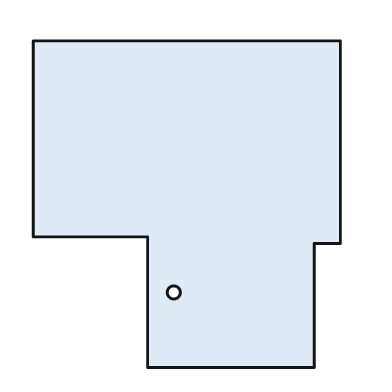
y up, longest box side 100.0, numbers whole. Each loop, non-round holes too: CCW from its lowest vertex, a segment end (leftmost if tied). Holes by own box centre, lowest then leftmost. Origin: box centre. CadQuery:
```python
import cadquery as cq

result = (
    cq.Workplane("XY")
    .moveTo(-12.0, -50.0)
    .lineTo(39.0, -50.0)
    .lineTo(39.0, -12.0)
    .lineTo(47.0, -12.0)
    .lineTo(47.0, 50.0)
    .lineTo(-47.0, 50.0)
    .lineTo(-47.0, -10.0)
    .lineTo(-12.0, -10.0)
    .close()
    .moveTo(-4.0, -27.0)
    .circle(2.0)
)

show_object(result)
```